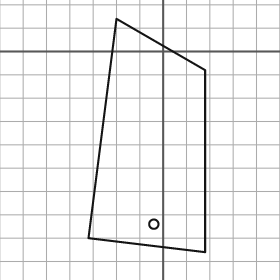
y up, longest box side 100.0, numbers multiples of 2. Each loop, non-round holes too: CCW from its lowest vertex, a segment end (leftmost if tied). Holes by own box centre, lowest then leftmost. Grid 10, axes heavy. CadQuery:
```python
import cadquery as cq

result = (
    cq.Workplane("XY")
    .moveTo(18.0, -86.0)
    .lineTo(18.0, -8.0)
    .lineTo(-20.0, 14.0)
    .lineTo(-32.0, -80.0)
    .close()
    .moveTo(-4.0, -74.0)
    .circle(2.0)
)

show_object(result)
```